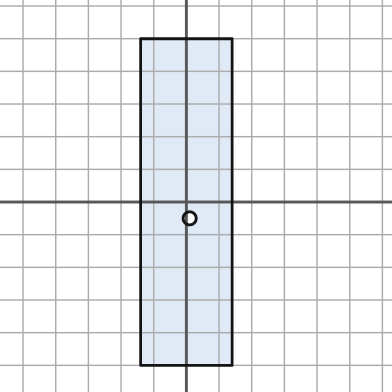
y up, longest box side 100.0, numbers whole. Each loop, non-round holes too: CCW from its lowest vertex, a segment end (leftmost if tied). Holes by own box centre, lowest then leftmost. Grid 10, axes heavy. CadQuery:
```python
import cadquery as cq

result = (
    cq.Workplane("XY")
    .moveTo(-14.0, -50.0)
    .lineTo(14.0, -50.0)
    .lineTo(14.0, 50.0)
    .lineTo(-14.0, 50.0)
    .close()
    .moveTo(1.0, -5.0)
    .circle(2.0)
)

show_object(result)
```